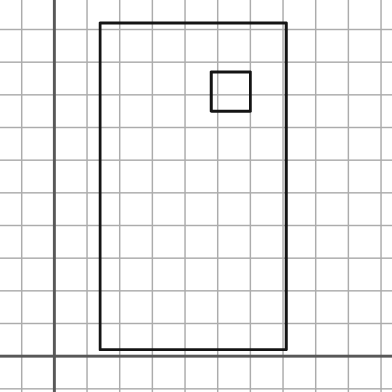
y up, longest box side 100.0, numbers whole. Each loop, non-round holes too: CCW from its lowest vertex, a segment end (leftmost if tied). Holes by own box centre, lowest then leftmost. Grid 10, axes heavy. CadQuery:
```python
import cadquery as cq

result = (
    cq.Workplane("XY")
    .moveTo(14.0, 2.0)
    .lineTo(71.0, 2.0)
    .lineTo(71.0, 102.0)
    .lineTo(14.0, 102.0)
    .close()
    .moveTo(48.0, 75.0)
    .lineTo(60.0, 75.0)
    .lineTo(60.0, 87.0)
    .lineTo(48.0, 87.0)
    .close()
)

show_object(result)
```